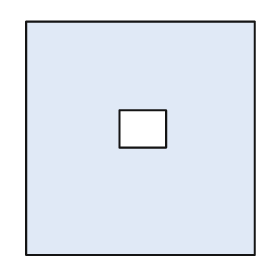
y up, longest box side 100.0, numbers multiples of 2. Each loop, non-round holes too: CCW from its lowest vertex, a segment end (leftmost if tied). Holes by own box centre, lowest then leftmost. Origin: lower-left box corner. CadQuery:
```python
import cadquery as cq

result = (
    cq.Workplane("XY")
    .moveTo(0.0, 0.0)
    .lineTo(98.0, 0.0)
    .lineTo(98.0, 100.0)
    .lineTo(0.0, 100.0)
    .close()
    .moveTo(40.0, 46.0)
    .lineTo(60.0, 46.0)
    .lineTo(60.0, 62.0)
    .lineTo(40.0, 62.0)
    .close()
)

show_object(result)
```